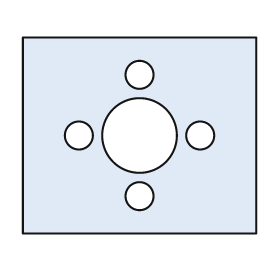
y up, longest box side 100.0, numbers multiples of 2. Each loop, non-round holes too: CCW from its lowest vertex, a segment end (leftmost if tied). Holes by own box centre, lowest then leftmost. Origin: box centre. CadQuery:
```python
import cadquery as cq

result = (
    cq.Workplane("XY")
    .moveTo(-50.0, -42.0)
    .lineTo(50.0, -42.0)
    .lineTo(50.0, 42.0)
    .lineTo(-50.0, 42.0)
    .close()
    .moveTo(0.0, -26.0)
    .circle(6.0)
    .moveTo(-26.0, 0.0)
    .circle(6.0)
    .moveTo(0.0, 0.0)
    .circle(16.0)
    .moveTo(26.0, 0.0)
    .circle(6.0)
    .moveTo(0.0, 26.0)
    .circle(6.0)
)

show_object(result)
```